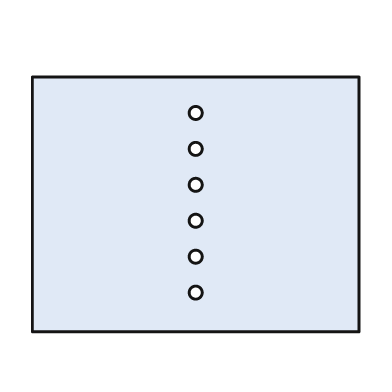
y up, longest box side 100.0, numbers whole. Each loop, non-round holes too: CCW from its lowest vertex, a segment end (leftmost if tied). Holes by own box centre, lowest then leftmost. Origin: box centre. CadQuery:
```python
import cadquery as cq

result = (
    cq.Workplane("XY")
    .moveTo(-50.0, -39.0)
    .lineTo(50.0, -39.0)
    .lineTo(50.0, 39.0)
    .lineTo(-50.0, 39.0)
    .close()
    .moveTo(0.0, -27.0)
    .circle(2.0)
    .moveTo(0.0, -16.0)
    .circle(2.0)
    .moveTo(0.0, -5.0)
    .circle(2.0)
    .moveTo(0.0, 6.0)
    .circle(2.0)
    .moveTo(0.0, 17.0)
    .circle(2.0)
    .moveTo(0.0, 28.0)
    .circle(2.0)
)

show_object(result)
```